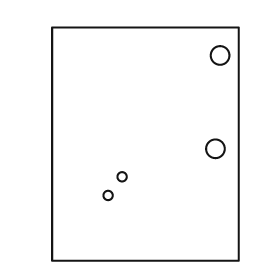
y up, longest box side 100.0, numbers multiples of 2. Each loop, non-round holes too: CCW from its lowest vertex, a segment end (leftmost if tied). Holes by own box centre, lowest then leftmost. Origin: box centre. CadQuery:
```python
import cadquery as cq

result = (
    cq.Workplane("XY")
    .moveTo(-40.0, -50.0)
    .lineTo(40.0, -50.0)
    .lineTo(40.0, 50.0)
    .lineTo(-40.0, 50.0)
    .close()
    .moveTo(-16.0, -22.0)
    .circle(2.0)
    .moveTo(-10.0, -14.0)
    .circle(2.0)
    .moveTo(30.0, -2.0)
    .circle(4.0)
    .moveTo(32.0, 38.0)
    .circle(4.0)
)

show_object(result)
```